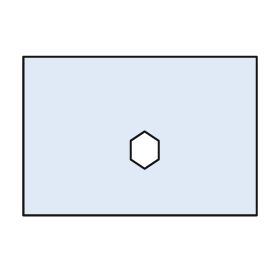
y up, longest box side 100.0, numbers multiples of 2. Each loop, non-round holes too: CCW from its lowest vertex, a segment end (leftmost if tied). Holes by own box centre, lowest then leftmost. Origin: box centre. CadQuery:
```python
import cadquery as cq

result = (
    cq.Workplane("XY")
    .moveTo(-50.0, -34.0)
    .lineTo(50.0, -34.0)
    .lineTo(50.0, 34.0)
    .lineTo(-50.0, 34.0)
    .close()
    .moveTo(2.0, -14.0)
    .lineTo(8.0, -10.0)
    .lineTo(8.0, -2.0)
    .lineTo(2.0, 2.0)
    .lineTo(-4.0, -2.0)
    .lineTo(-4.0, -10.0)
    .close()
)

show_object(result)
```